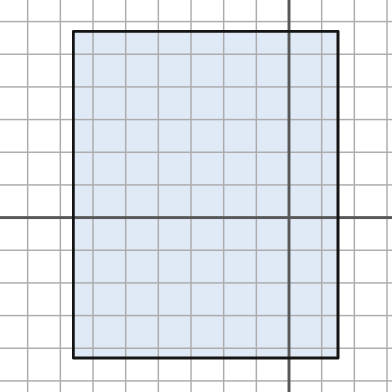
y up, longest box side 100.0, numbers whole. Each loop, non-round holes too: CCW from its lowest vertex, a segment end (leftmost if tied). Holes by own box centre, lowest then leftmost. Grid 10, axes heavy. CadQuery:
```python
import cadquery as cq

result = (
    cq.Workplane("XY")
    .moveTo(-66.0, -43.0)
    .lineTo(15.0, -43.0)
    .lineTo(15.0, 57.0)
    .lineTo(-66.0, 57.0)
    .close()
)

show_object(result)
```